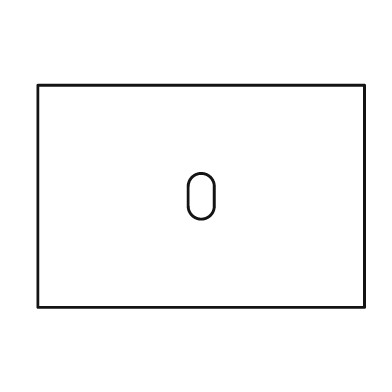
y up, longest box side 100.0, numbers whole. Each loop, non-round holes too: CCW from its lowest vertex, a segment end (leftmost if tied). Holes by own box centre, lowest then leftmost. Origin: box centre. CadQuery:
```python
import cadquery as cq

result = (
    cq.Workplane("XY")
    .moveTo(-50.0, -34.0)
    .lineTo(50.0, -34.0)
    .lineTo(50.0, 34.0)
    .lineTo(-50.0, 34.0)
    .close()
    .moveTo(-4.0, -3.0)
    .threePointArc((0.0, -7.0), (4.0, -3.0))
    .lineTo(4.0, 3.0)
    .threePointArc((0.0, 7.0), (-4.0, 3.0))
    .close()
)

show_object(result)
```